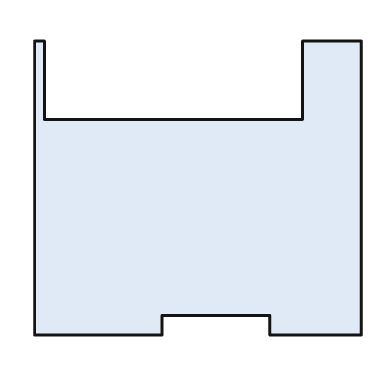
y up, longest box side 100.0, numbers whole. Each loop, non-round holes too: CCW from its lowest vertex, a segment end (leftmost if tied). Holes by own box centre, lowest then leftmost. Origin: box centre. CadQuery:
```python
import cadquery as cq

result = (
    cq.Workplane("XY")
    .moveTo(-50.0, -45.0)
    .lineTo(-11.0, -45.0)
    .lineTo(-11.0, -39.0)
    .lineTo(22.0, -39.0)
    .lineTo(22.0, -45.0)
    .lineTo(50.0, -45.0)
    .lineTo(50.0, 45.0)
    .lineTo(32.0, 45.0)
    .lineTo(32.0, 21.0)
    .lineTo(-47.0, 21.0)
    .lineTo(-47.0, 45.0)
    .lineTo(-50.0, 45.0)
    .close()
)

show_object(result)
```